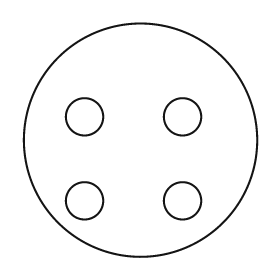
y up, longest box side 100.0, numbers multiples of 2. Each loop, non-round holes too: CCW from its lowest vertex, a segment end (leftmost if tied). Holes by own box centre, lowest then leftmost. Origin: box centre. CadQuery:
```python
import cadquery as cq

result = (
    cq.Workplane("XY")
    .moveTo(0.0, 0.0)
    .circle(50.0)
    .moveTo(-24.0, -26.0)
    .circle(8.0)
    .moveTo(18.0, -26.0)
    .circle(8.0)
    .moveTo(-24.0, 10.0)
    .circle(8.0)
    .moveTo(18.0, 10.0)
    .circle(8.0)
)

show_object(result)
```